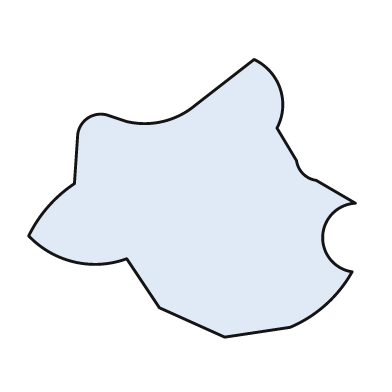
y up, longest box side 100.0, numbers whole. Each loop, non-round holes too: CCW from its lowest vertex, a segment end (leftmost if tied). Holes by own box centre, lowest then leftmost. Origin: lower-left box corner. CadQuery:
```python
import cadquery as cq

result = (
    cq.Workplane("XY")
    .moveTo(60.0, 0.0)
    .lineTo(80.0, 3.0)
    .threePointArc((91.0, 10.0), (99.0, 20.0))
    .threePointArc((90.0, 31.0), (100.0, 41.0))
    .lineTo(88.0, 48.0)
    .threePointArc((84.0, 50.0), (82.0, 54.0))
    .lineTo(76.0, 64.0)
    .threePointArc((77.0, 76.0), (69.0, 85.0))
    .lineTo(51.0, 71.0)
    .threePointArc((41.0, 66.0), (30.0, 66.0))
    .lineTo(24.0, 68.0)
    .threePointArc((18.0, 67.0), (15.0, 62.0))
    .lineTo(14.0, 47.0)
    .threePointArc((6.0, 40.0), (0.0, 31.0))
    .threePointArc((14.0, 23.0), (30.0, 24.0))
    .lineTo(40.0, 9.0)
    .close()
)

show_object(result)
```